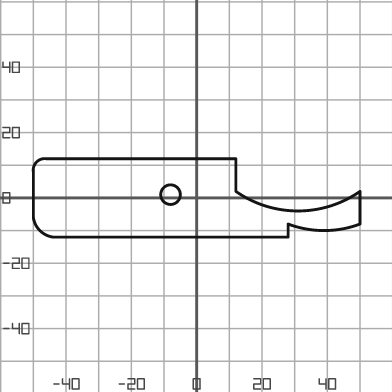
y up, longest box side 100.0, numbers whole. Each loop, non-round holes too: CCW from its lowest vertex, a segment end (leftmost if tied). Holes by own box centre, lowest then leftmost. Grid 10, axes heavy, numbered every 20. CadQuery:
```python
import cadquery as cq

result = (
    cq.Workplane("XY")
    .moveTo(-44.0, -12.0)
    .lineTo(28.0, -12.0)
    .lineTo(28.0, -8.0)
    .threePointArc((39.0, -10.0), (50.0, -8.0))
    .lineTo(50.0, 2.0)
    .threePointArc((31.0, -4.0), (12.0, 2.0))
    .lineTo(12.0, 12.0)
    .lineTo(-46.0, 12.0)
    .threePointArc((-49.0, 11.0), (-50.0, 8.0))
    .lineTo(-50.0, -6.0)
    .threePointArc((-48.0, -10.0), (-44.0, -12.0))
    .close()
    .moveTo(-8.0, 1.0)
    .circle(3.0)
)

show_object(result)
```